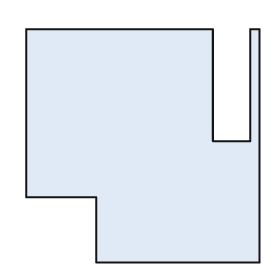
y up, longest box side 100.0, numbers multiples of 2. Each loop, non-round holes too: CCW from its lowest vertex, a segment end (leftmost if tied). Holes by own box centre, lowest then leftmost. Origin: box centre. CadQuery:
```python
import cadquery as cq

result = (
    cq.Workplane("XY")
    .moveTo(-20.0, -50.0)
    .lineTo(50.0, -50.0)
    .lineTo(50.0, 50.0)
    .lineTo(46.0, 50.0)
    .lineTo(46.0, 2.0)
    .lineTo(30.0, 2.0)
    .lineTo(30.0, 50.0)
    .lineTo(-50.0, 50.0)
    .lineTo(-50.0, -22.0)
    .lineTo(-20.0, -22.0)
    .close()
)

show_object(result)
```